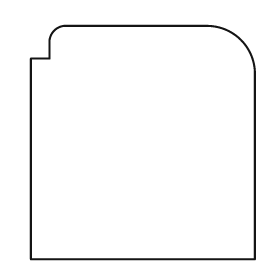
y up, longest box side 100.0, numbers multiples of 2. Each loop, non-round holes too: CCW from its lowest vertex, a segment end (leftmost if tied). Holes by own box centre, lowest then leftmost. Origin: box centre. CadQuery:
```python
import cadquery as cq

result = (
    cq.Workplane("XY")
    .moveTo(-48.0, -50.0)
    .lineTo(48.0, -50.0)
    .lineTo(48.0, 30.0)
    .threePointArc((42.0, 44.0), (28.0, 50.0))
    .lineTo(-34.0, 50.0)
    .threePointArc((-38.0, 48.0), (-40.0, 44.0))
    .lineTo(-40.0, 36.0)
    .lineTo(-48.0, 36.0)
    .close()
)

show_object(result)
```